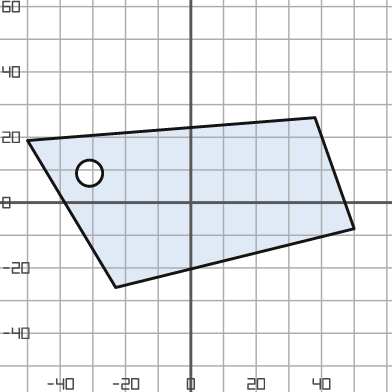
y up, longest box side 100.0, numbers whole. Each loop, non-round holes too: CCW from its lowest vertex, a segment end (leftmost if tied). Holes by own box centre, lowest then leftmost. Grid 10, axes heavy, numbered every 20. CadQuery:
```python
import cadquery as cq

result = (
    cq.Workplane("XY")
    .moveTo(-23.0, -26.0)
    .lineTo(50.0, -8.0)
    .lineTo(38.0, 26.0)
    .lineTo(-50.0, 19.0)
    .close()
    .moveTo(-31.0, 9.0)
    .circle(4.0)
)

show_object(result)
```